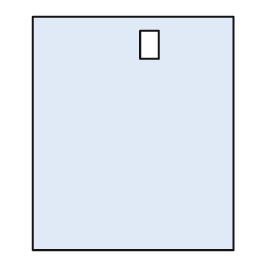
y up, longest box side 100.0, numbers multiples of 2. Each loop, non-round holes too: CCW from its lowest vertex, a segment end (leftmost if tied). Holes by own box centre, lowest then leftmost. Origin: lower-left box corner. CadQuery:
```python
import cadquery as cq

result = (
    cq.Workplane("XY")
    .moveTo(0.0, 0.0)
    .lineTo(86.0, 0.0)
    .lineTo(86.0, 100.0)
    .lineTo(0.0, 100.0)
    .close()
    .moveTo(46.0, 82.0)
    .lineTo(54.0, 82.0)
    .lineTo(54.0, 94.0)
    .lineTo(46.0, 94.0)
    .close()
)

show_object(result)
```